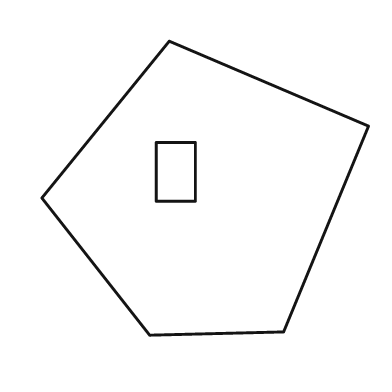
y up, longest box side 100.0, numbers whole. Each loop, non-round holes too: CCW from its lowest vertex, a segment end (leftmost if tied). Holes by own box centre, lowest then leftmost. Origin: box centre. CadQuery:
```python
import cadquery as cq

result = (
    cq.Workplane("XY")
    .moveTo(-17.0, -45.0)
    .lineTo(24.0, -44.0)
    .lineTo(50.0, 19.0)
    .lineTo(-11.0, 45.0)
    .lineTo(-50.0, -3.0)
    .close()
    .moveTo(-15.0, -4.0)
    .lineTo(-3.0, -4.0)
    .lineTo(-3.0, 14.0)
    .lineTo(-15.0, 14.0)
    .close()
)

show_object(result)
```